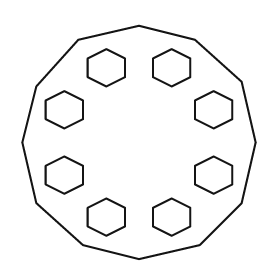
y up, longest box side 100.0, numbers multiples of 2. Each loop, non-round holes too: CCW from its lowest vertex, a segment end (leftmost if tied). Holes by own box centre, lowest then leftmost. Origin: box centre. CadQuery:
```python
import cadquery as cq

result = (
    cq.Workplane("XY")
    .moveTo(0.0, -50.0)
    .lineTo(26.0, -44.0)
    .lineTo(44.0, -26.0)
    .lineTo(50.0, 0.0)
    .lineTo(44.0, 26.0)
    .lineTo(24.0, 44.0)
    .lineTo(0.0, 50.0)
    .lineTo(-26.0, 44.0)
    .lineTo(-44.0, 24.0)
    .lineTo(-50.0, 0.0)
    .lineTo(-44.0, -26.0)
    .lineTo(-24.0, -44.0)
    .close()
    .moveTo(-14.0, -40.0)
    .lineTo(-6.0, -36.0)
    .lineTo(-6.0, -28.0)
    .lineTo(-14.0, -24.0)
    .lineTo(-22.0, -28.0)
    .lineTo(-22.0, -36.0)
    .close()
    .moveTo(14.0, -40.0)
    .lineTo(22.0, -36.0)
    .lineTo(22.0, -28.0)
    .lineTo(14.0, -24.0)
    .lineTo(6.0, -28.0)
    .lineTo(6.0, -36.0)
    .close()
    .moveTo(-32.0, -22.0)
    .lineTo(-24.0, -18.0)
    .lineTo(-24.0, -10.0)
    .lineTo(-32.0, -6.0)
    .lineTo(-40.0, -10.0)
    .lineTo(-40.0, -18.0)
    .close()
    .moveTo(32.0, -22.0)
    .lineTo(40.0, -18.0)
    .lineTo(40.0, -10.0)
    .lineTo(32.0, -6.0)
    .lineTo(24.0, -10.0)
    .lineTo(24.0, -18.0)
    .close()
    .moveTo(-32.0, 6.0)
    .lineTo(-24.0, 10.0)
    .lineTo(-24.0, 18.0)
    .lineTo(-32.0, 22.0)
    .lineTo(-40.0, 18.0)
    .lineTo(-40.0, 10.0)
    .close()
    .moveTo(32.0, 6.0)
    .lineTo(40.0, 10.0)
    .lineTo(40.0, 18.0)
    .lineTo(32.0, 22.0)
    .lineTo(24.0, 18.0)
    .lineTo(24.0, 10.0)
    .close()
    .moveTo(-14.0, 24.0)
    .lineTo(-6.0, 28.0)
    .lineTo(-6.0, 36.0)
    .lineTo(-14.0, 40.0)
    .lineTo(-22.0, 36.0)
    .lineTo(-22.0, 28.0)
    .close()
    .moveTo(14.0, 24.0)
    .lineTo(22.0, 28.0)
    .lineTo(22.0, 36.0)
    .lineTo(14.0, 40.0)
    .lineTo(6.0, 36.0)
    .lineTo(6.0, 28.0)
    .close()
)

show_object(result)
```